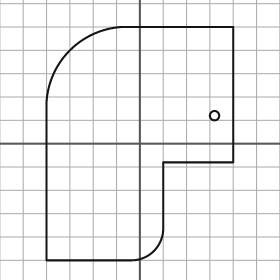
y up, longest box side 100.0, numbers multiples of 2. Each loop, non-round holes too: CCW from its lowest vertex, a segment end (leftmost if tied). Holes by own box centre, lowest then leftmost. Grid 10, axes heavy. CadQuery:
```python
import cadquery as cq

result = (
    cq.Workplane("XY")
    .moveTo(-40.0, -50.0)
    .lineTo(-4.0, -50.0)
    .threePointArc((6.0, -46.0), (10.0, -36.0))
    .lineTo(10.0, -8.0)
    .lineTo(40.0, -8.0)
    .lineTo(40.0, 50.0)
    .lineTo(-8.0, 50.0)
    .threePointArc((-30.0, 40.0), (-40.0, 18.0))
    .close()
    .moveTo(32.0, 12.0)
    .circle(2.0)
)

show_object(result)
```